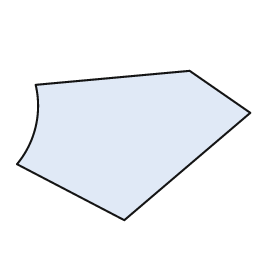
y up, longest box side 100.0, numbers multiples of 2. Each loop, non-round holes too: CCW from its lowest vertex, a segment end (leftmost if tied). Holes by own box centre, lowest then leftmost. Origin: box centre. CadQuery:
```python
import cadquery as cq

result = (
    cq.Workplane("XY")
    .moveTo(-4.0, -32.0)
    .lineTo(50.0, 14.0)
    .lineTo(24.0, 32.0)
    .lineTo(-42.0, 26.0)
    .threePointArc((-42.0, 8.0), (-50.0, -8.0))
    .close()
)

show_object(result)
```